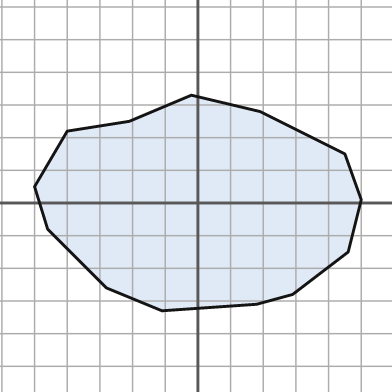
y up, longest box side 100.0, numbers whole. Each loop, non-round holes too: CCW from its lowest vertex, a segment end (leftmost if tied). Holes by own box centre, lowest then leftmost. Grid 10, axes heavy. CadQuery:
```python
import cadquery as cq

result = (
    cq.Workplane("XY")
    .moveTo(-11.0, -33.0)
    .lineTo(18.0, -31.0)
    .lineTo(29.0, -28.0)
    .lineTo(46.0, -15.0)
    .lineTo(50.0, 1.0)
    .lineTo(45.0, 15.0)
    .lineTo(19.0, 28.0)
    .lineTo(-2.0, 33.0)
    .lineTo(-21.0, 25.0)
    .lineTo(-40.0, 22.0)
    .lineTo(-50.0, 5.0)
    .lineTo(-46.0, -8.0)
    .lineTo(-28.0, -26.0)
    .close()
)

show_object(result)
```